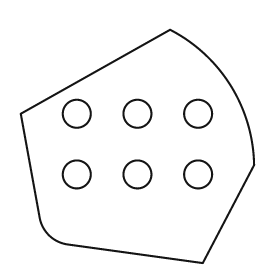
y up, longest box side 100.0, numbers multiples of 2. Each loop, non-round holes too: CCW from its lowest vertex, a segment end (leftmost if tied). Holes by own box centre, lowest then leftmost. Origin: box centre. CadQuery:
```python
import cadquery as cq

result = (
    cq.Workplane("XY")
    .moveTo(28.0, -50.0)
    .lineTo(50.0, -8.0)
    .threePointArc((40.0, 26.0), (14.0, 50.0))
    .lineTo(-50.0, 14.0)
    .lineTo(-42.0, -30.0)
    .threePointArc((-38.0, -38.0), (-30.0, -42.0))
    .close()
    .moveTo(-26.0, -12.0)
    .circle(6.0)
    .moveTo(0.0, -12.0)
    .circle(6.0)
    .moveTo(26.0, -12.0)
    .circle(6.0)
    .moveTo(-26.0, 14.0)
    .circle(6.0)
    .moveTo(0.0, 14.0)
    .circle(6.0)
    .moveTo(26.0, 14.0)
    .circle(6.0)
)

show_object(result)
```